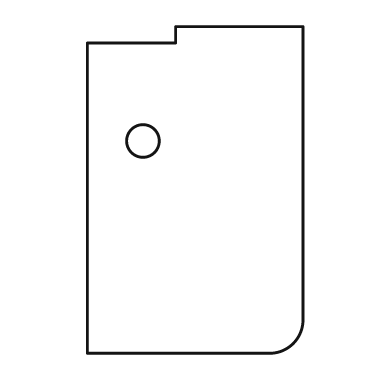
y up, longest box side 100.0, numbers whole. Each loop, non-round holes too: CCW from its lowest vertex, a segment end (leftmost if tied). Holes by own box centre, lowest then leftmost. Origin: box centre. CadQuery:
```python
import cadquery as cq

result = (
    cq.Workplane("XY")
    .moveTo(-33.0, -50.0)
    .lineTo(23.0, -50.0)
    .threePointArc((30.0, -47.0), (33.0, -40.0))
    .lineTo(33.0, 50.0)
    .lineTo(-6.0, 50.0)
    .lineTo(-6.0, 45.0)
    .lineTo(-33.0, 45.0)
    .close()
    .moveTo(-16.0, 15.0)
    .circle(5.0)
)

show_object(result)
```